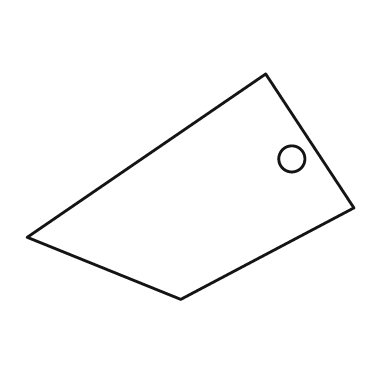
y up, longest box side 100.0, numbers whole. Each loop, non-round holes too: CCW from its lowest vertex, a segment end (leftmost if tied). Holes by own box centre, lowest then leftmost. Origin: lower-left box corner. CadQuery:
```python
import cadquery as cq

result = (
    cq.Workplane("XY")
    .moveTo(47.0, 0.0)
    .lineTo(100.0, 28.0)
    .lineTo(73.0, 69.0)
    .lineTo(0.0, 19.0)
    .close()
    .moveTo(81.0, 43.0)
    .circle(4.0)
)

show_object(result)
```